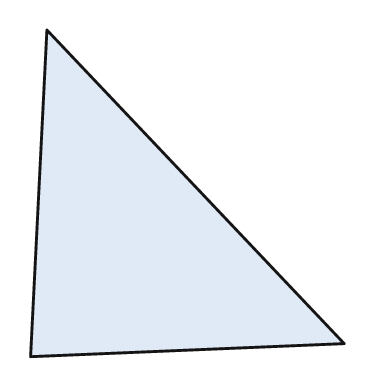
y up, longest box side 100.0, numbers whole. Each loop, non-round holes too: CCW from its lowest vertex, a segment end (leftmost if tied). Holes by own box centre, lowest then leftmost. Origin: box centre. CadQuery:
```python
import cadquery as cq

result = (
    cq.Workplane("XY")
    .moveTo(-48.0, -50.0)
    .lineTo(48.0, -46.0)
    .lineTo(-43.0, 50.0)
    .close()
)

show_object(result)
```